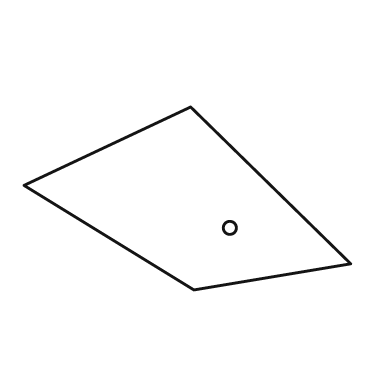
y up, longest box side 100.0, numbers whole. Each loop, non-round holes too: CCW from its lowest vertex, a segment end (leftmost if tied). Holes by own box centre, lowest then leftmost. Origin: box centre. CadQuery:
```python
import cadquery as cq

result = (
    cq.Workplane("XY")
    .moveTo(2.0, -28.0)
    .lineTo(50.0, -20.0)
    .lineTo(1.0, 28.0)
    .lineTo(-50.0, 4.0)
    .close()
    .moveTo(13.0, -9.0)
    .circle(2.0)
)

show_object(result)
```